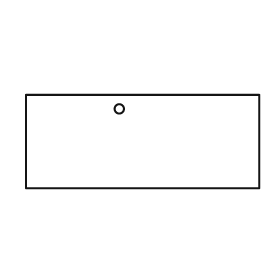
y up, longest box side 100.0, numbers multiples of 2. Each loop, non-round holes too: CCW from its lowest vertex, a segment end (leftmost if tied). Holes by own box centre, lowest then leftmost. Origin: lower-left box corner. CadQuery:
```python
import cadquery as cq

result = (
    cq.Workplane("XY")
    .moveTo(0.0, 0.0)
    .lineTo(100.0, 0.0)
    .lineTo(100.0, 40.0)
    .lineTo(0.0, 40.0)
    .close()
    .moveTo(40.0, 34.0)
    .circle(2.0)
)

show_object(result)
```